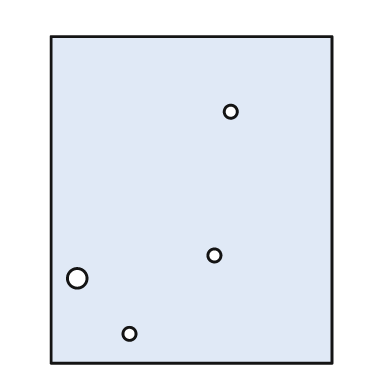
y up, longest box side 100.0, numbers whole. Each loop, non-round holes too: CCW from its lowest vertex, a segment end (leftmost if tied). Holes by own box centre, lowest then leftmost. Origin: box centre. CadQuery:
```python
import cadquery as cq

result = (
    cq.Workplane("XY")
    .moveTo(-43.0, -50.0)
    .lineTo(43.0, -50.0)
    .lineTo(43.0, 50.0)
    .lineTo(-43.0, 50.0)
    .close()
    .moveTo(-19.0, -41.0)
    .circle(2.0)
    .moveTo(-35.0, -24.0)
    .circle(3.0)
    .moveTo(7.0, -17.0)
    .circle(2.0)
    .moveTo(12.0, 27.0)
    .circle(2.0)
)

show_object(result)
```